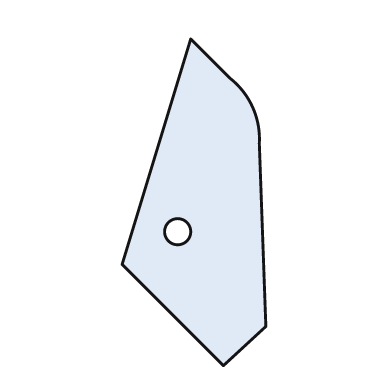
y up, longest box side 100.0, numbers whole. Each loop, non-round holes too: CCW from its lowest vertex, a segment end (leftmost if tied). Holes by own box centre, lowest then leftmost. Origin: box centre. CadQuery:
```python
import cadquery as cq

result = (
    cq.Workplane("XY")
    .moveTo(9.0, -50.0)
    .lineTo(22.0, -38.0)
    .lineTo(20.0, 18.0)
    .threePointArc((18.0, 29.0), (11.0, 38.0))
    .lineTo(-1.0, 50.0)
    .lineTo(-22.0, -19.0)
    .close()
    .moveTo(-5.0, -9.0)
    .circle(4.0)
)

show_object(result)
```